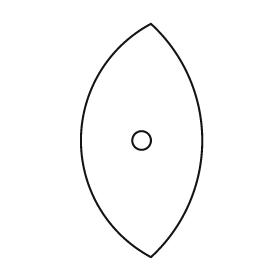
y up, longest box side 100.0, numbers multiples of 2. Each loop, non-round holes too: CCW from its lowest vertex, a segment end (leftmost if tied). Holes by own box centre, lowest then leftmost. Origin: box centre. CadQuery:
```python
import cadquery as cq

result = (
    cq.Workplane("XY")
    .moveTo(4.0, -50.0)
    .threePointArc((26.0, 0.0), (4.0, 50.0))
    .threePointArc((-26.0, 0.0), (4.0, -50.0))
    .close()
    .moveTo(0.0, 0.0)
    .circle(4.0)
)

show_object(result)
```